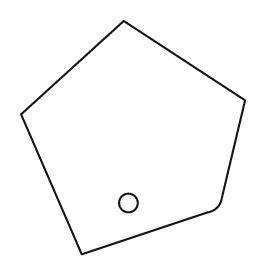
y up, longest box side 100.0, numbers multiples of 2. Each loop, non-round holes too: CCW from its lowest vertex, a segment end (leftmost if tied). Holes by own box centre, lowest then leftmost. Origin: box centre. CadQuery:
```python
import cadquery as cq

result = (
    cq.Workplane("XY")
    .moveTo(-22.0, -50.0)
    .lineTo(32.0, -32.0)
    .threePointArc((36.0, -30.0), (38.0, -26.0))
    .lineTo(48.0, 16.0)
    .lineTo(-4.0, 50.0)
    .lineTo(-48.0, 10.0)
    .close()
    .moveTo(-2.0, -28.0)
    .circle(4.0)
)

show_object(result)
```